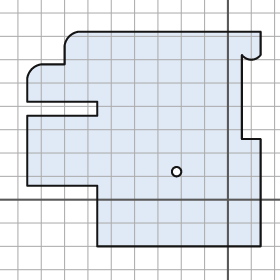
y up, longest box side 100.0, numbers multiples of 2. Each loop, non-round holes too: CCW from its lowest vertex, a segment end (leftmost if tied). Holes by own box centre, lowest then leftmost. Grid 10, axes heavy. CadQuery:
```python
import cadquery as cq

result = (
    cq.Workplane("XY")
    .moveTo(-56.0, -20.0)
    .lineTo(14.0, -20.0)
    .lineTo(14.0, 26.0)
    .lineTo(6.0, 26.0)
    .lineTo(6.0, 62.0)
    .threePointArc((10.0, 60.0), (14.0, 62.0))
    .lineTo(14.0, 72.0)
    .lineTo(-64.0, 72.0)
    .threePointArc((-68.0, 70.0), (-70.0, 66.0))
    .lineTo(-70.0, 58.0)
    .lineTo(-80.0, 58.0)
    .threePointArc((-84.0, 56.0), (-86.0, 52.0))
    .lineTo(-86.0, 42.0)
    .lineTo(-56.0, 42.0)
    .lineTo(-56.0, 36.0)
    .lineTo(-86.0, 36.0)
    .lineTo(-86.0, 6.0)
    .lineTo(-56.0, 6.0)
    .close()
    .moveTo(-22.0, 12.0)
    .circle(2.0)
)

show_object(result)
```